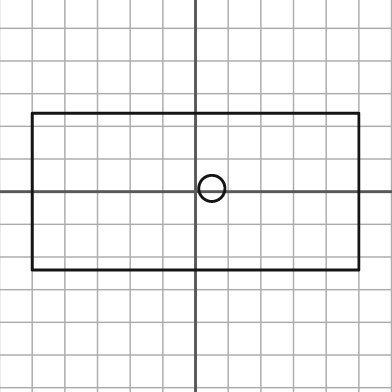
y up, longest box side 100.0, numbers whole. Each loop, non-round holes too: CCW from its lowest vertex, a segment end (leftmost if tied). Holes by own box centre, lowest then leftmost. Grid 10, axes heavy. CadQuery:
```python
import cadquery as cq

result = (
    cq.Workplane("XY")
    .moveTo(-50.0, -24.0)
    .lineTo(50.0, -24.0)
    .lineTo(50.0, 24.0)
    .lineTo(-50.0, 24.0)
    .close()
    .moveTo(5.0, 1.0)
    .circle(4.0)
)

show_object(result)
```